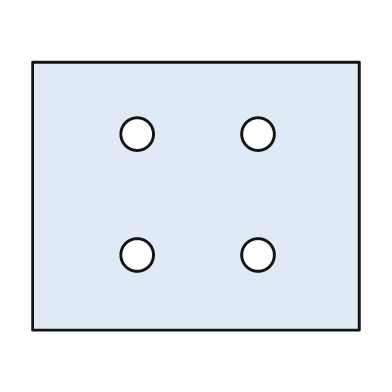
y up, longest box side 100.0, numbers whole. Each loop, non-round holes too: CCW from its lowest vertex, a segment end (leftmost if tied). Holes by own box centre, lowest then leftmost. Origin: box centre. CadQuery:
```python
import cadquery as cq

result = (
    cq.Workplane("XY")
    .moveTo(-50.0, -41.0)
    .lineTo(50.0, -41.0)
    .lineTo(50.0, 41.0)
    .lineTo(-50.0, 41.0)
    .close()
    .moveTo(-18.0, -18.0)
    .circle(5.0)
    .moveTo(19.0, -18.0)
    .circle(5.0)
    .moveTo(-18.0, 19.0)
    .circle(5.0)
    .moveTo(19.0, 19.0)
    .circle(5.0)
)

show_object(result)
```